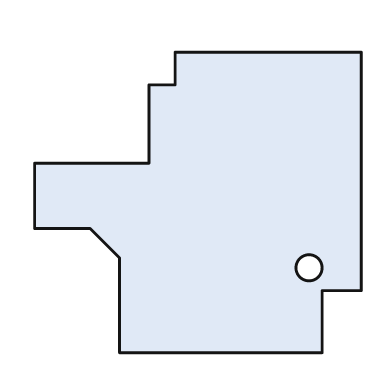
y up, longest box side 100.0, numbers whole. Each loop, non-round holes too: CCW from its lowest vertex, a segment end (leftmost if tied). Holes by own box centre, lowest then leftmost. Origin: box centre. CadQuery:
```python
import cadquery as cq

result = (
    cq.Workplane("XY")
    .moveTo(-24.0, -46.0)
    .lineTo(38.0, -46.0)
    .lineTo(38.0, -27.0)
    .lineTo(50.0, -27.0)
    .lineTo(50.0, 46.0)
    .lineTo(-7.0, 46.0)
    .lineTo(-7.0, 36.0)
    .lineTo(-15.0, 36.0)
    .lineTo(-15.0, 12.0)
    .lineTo(-50.0, 12.0)
    .lineTo(-50.0, -8.0)
    .lineTo(-33.0, -8.0)
    .lineTo(-24.0, -17.0)
    .close()
    .moveTo(34.0, -20.0)
    .circle(4.0)
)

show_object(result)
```